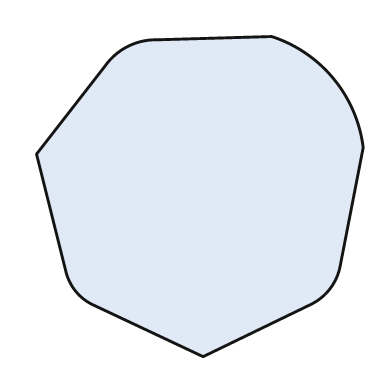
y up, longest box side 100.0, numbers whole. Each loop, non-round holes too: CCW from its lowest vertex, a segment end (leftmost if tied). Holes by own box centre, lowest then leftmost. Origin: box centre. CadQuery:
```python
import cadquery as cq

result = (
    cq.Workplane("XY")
    .moveTo(1.0, -49.0)
    .lineTo(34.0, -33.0)
    .threePointArc((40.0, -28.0), (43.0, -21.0))
    .lineTo(50.0, 15.0)
    .threePointArc((41.0, 36.0), (22.0, 49.0))
    .lineTo(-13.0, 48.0)
    .threePointArc((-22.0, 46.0), (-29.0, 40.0))
    .lineTo(-50.0, 13.0)
    .lineTo(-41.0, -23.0)
    .threePointArc((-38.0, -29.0), (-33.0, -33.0))
    .close()
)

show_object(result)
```